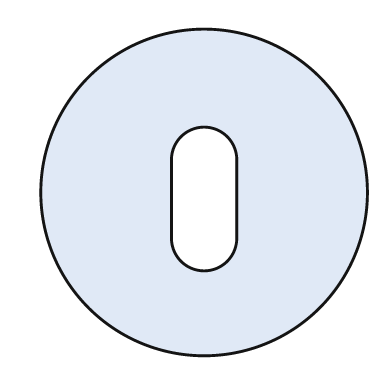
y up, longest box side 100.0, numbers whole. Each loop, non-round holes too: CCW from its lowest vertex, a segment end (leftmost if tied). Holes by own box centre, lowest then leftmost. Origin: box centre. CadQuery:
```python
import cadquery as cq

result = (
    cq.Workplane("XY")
    .moveTo(0.0, 0.0)
    .circle(50.0)
    .moveTo(-10.0, -14.0)
    .threePointArc((0.0, -24.0), (10.0, -14.0))
    .lineTo(10.0, 10.0)
    .threePointArc((0.0, 20.0), (-10.0, 10.0))
    .close()
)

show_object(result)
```